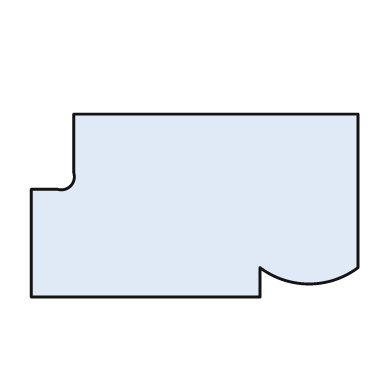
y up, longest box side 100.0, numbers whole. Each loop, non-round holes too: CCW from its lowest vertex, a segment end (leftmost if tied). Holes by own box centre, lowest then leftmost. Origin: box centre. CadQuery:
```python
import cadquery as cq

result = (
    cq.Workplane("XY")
    .moveTo(-50.0, -28.0)
    .lineTo(20.0, -28.0)
    .lineTo(20.0, -19.0)
    .threePointArc((35.0, -24.0), (50.0, -19.0))
    .lineTo(50.0, 28.0)
    .lineTo(-37.0, 28.0)
    .lineTo(-37.0, 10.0)
    .threePointArc((-38.0, 6.0), (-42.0, 5.0))
    .lineTo(-50.0, 5.0)
    .close()
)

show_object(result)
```